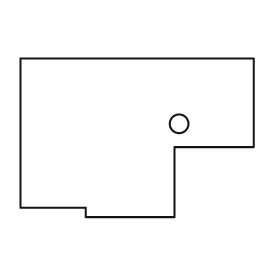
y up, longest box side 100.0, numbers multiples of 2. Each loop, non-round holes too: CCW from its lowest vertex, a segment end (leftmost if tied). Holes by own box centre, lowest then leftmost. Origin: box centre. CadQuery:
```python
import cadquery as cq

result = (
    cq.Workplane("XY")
    .moveTo(-22.0, -34.0)
    .lineTo(16.0, -34.0)
    .lineTo(16.0, -4.0)
    .lineTo(50.0, -4.0)
    .lineTo(50.0, 34.0)
    .lineTo(-50.0, 34.0)
    .lineTo(-50.0, -30.0)
    .lineTo(-22.0, -30.0)
    .close()
    .moveTo(18.0, 6.0)
    .circle(4.0)
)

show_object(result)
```